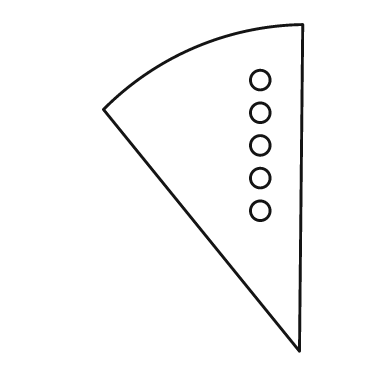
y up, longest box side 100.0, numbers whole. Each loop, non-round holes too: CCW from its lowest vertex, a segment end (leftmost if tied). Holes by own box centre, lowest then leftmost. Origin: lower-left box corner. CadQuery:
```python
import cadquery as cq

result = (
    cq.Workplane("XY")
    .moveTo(60.0, 0.0)
    .lineTo(61.0, 100.0)
    .threePointArc((28.0, 93.0), (0.0, 74.0))
    .close()
    .moveTo(48.0, 43.0)
    .circle(3.0)
    .moveTo(48.0, 53.0)
    .circle(3.0)
    .moveTo(48.0, 63.0)
    .circle(3.0)
    .moveTo(48.0, 73.0)
    .circle(3.0)
    .moveTo(48.0, 83.0)
    .circle(3.0)
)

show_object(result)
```